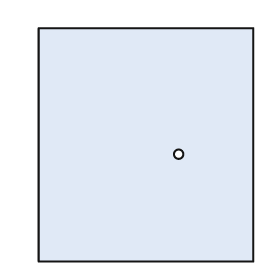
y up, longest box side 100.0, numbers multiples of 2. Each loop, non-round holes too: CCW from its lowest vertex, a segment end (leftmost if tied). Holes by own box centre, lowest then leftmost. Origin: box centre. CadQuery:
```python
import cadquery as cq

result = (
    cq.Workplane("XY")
    .moveTo(-46.0, -50.0)
    .lineTo(46.0, -50.0)
    .lineTo(46.0, 50.0)
    .lineTo(-46.0, 50.0)
    .close()
    .moveTo(14.0, -4.0)
    .circle(2.0)
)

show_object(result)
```